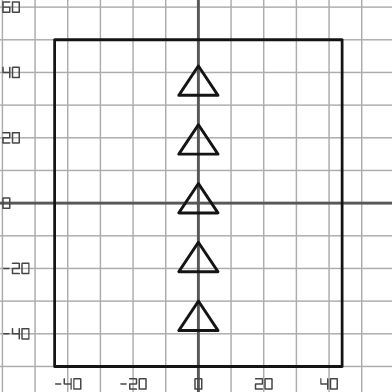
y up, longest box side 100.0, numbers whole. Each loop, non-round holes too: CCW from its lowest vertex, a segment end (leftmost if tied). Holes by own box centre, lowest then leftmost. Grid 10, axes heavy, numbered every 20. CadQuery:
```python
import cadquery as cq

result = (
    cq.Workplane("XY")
    .moveTo(-44.0, -50.0)
    .lineTo(44.0, -50.0)
    .lineTo(44.0, 50.0)
    .lineTo(-44.0, 50.0)
    .close()
    .moveTo(-6.0, -39.0)
    .lineTo(6.0, -39.0)
    .lineTo(0.0, -30.0)
    .close()
    .moveTo(-6.0, -21.0)
    .lineTo(6.0, -21.0)
    .lineTo(0.0, -12.0)
    .close()
    .moveTo(-6.0, -3.0)
    .lineTo(6.0, -3.0)
    .lineTo(0.0, 6.0)
    .close()
    .moveTo(-6.0, 15.0)
    .lineTo(6.0, 15.0)
    .lineTo(0.0, 24.0)
    .close()
    .moveTo(-6.0, 33.0)
    .lineTo(6.0, 33.0)
    .lineTo(0.0, 42.0)
    .close()
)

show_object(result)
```